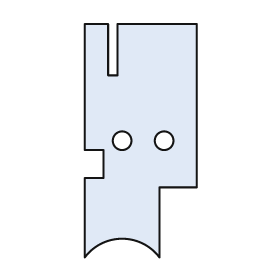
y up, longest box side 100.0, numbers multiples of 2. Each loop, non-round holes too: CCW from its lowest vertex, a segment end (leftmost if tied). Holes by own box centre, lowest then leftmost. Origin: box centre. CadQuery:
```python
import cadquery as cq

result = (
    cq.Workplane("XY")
    .moveTo(-24.0, -50.0)
    .threePointArc((-8.0, -42.0), (8.0, -50.0))
    .lineTo(8.0, -20.0)
    .lineTo(24.0, -20.0)
    .lineTo(24.0, 50.0)
    .lineTo(-10.0, 50.0)
    .lineTo(-10.0, 28.0)
    .lineTo(-14.0, 28.0)
    .lineTo(-14.0, 50.0)
    .lineTo(-24.0, 50.0)
    .lineTo(-24.0, -4.0)
    .lineTo(-16.0, -4.0)
    .lineTo(-16.0, -16.0)
    .lineTo(-24.0, -16.0)
    .close()
    .moveTo(-8.0, 0.0)
    .circle(4.0)
    .moveTo(10.0, 0.0)
    .circle(4.0)
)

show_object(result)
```